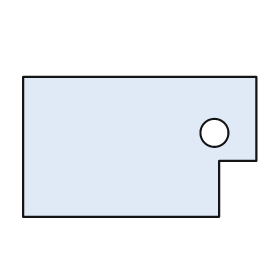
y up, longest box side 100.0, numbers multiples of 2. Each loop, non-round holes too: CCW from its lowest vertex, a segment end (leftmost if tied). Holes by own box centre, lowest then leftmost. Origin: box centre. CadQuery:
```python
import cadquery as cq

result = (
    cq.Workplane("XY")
    .moveTo(-50.0, -30.0)
    .lineTo(34.0, -30.0)
    .lineTo(34.0, -6.0)
    .lineTo(50.0, -6.0)
    .lineTo(50.0, 30.0)
    .lineTo(-50.0, 30.0)
    .close()
    .moveTo(32.0, 6.0)
    .circle(6.0)
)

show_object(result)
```